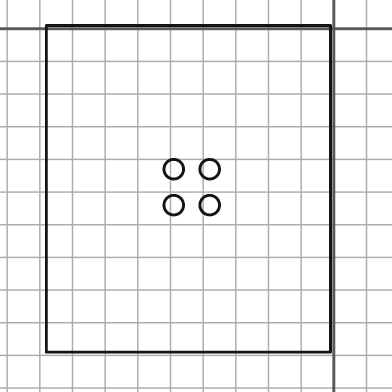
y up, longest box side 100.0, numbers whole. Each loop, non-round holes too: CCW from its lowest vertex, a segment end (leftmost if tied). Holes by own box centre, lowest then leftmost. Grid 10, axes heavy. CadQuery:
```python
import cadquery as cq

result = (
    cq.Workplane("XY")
    .moveTo(-88.0, -99.0)
    .lineTo(-1.0, -99.0)
    .lineTo(-1.0, 1.0)
    .lineTo(-88.0, 1.0)
    .close()
    .moveTo(-49.0, -54.0)
    .circle(3.0)
    .moveTo(-38.0, -54.0)
    .circle(3.0)
    .moveTo(-49.0, -43.0)
    .circle(3.0)
    .moveTo(-38.0, -43.0)
    .circle(3.0)
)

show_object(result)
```